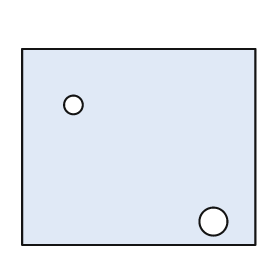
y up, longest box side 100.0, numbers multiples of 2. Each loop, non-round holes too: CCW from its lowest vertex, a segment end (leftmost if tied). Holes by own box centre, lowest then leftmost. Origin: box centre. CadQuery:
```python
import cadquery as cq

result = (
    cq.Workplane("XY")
    .moveTo(-50.0, -42.0)
    .lineTo(50.0, -42.0)
    .lineTo(50.0, 42.0)
    .lineTo(-50.0, 42.0)
    .close()
    .moveTo(32.0, -32.0)
    .circle(6.0)
    .moveTo(-28.0, 18.0)
    .circle(4.0)
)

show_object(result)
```